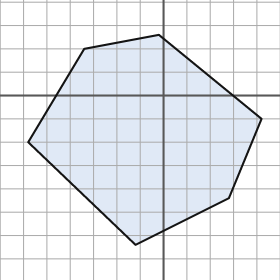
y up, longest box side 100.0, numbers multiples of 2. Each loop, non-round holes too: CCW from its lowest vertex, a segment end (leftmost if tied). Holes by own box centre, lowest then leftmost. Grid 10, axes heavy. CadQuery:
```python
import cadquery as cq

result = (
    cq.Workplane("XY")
    .moveTo(-12.0, -64.0)
    .lineTo(28.0, -44.0)
    .lineTo(42.0, -10.0)
    .lineTo(-2.0, 26.0)
    .lineTo(-34.0, 20.0)
    .lineTo(-58.0, -20.0)
    .close()
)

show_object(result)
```